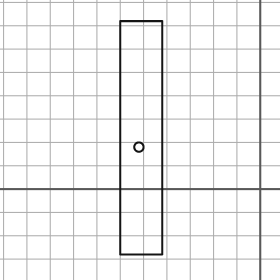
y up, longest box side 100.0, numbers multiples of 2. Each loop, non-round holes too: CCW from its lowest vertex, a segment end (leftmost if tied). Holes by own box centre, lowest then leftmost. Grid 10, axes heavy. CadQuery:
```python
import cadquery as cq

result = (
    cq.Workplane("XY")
    .moveTo(-60.0, -28.0)
    .lineTo(-42.0, -28.0)
    .lineTo(-42.0, 72.0)
    .lineTo(-60.0, 72.0)
    .close()
    .moveTo(-52.0, 18.0)
    .circle(2.0)
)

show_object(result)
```